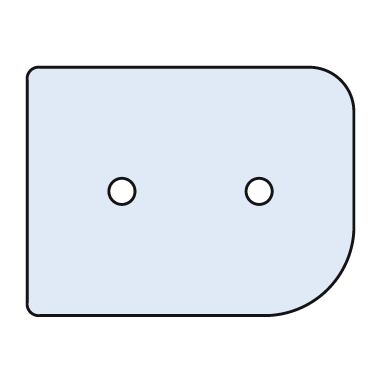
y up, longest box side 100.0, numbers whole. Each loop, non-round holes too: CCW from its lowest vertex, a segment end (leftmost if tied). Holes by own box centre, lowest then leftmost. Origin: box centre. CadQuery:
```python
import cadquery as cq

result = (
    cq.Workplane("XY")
    .moveTo(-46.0, -38.0)
    .lineTo(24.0, -38.0)
    .threePointArc((42.0, -30.0), (50.0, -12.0))
    .lineTo(50.0, 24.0)
    .threePointArc((46.0, 34.0), (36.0, 38.0))
    .lineTo(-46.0, 38.0)
    .threePointArc((-49.0, 37.0), (-50.0, 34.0))
    .lineTo(-50.0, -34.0)
    .threePointArc((-49.0, -37.0), (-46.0, -38.0))
    .close()
    .moveTo(-21.0, 0.0)
    .circle(4.0)
    .moveTo(21.0, 0.0)
    .circle(4.0)
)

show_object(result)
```